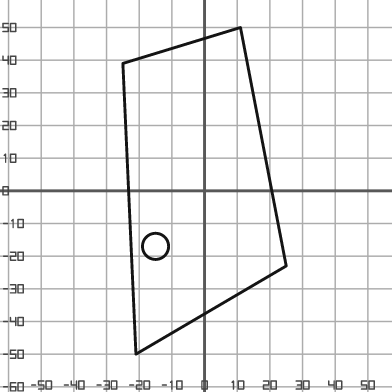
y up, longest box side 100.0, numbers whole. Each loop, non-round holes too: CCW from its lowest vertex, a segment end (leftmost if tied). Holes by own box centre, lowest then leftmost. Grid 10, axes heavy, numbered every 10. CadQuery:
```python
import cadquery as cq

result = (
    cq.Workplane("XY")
    .moveTo(-21.0, -50.0)
    .lineTo(25.0, -23.0)
    .lineTo(11.0, 50.0)
    .lineTo(-25.0, 39.0)
    .close()
    .moveTo(-15.0, -17.0)
    .circle(4.0)
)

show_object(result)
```